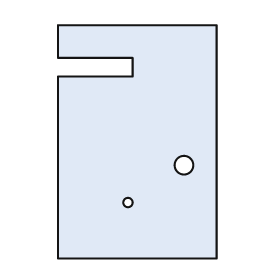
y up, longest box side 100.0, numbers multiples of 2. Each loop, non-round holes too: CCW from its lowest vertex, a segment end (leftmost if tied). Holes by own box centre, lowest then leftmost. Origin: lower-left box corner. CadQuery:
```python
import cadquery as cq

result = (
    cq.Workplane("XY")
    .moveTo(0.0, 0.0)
    .lineTo(68.0, 0.0)
    .lineTo(68.0, 100.0)
    .lineTo(0.0, 100.0)
    .lineTo(0.0, 86.0)
    .lineTo(32.0, 86.0)
    .lineTo(32.0, 78.0)
    .lineTo(0.0, 78.0)
    .close()
    .moveTo(30.0, 24.0)
    .circle(2.0)
    .moveTo(54.0, 40.0)
    .circle(4.0)
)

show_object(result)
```